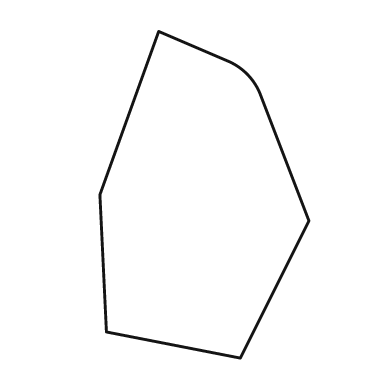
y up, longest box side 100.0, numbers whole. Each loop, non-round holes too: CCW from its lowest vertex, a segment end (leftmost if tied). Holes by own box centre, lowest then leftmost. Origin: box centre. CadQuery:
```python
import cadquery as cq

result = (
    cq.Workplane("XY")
    .moveTo(11.0, -50.0)
    .lineTo(32.0, -8.0)
    .lineTo(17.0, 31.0)
    .threePointArc((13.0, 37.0), (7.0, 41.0))
    .lineTo(-14.0, 50.0)
    .lineTo(-32.0, 0.0)
    .lineTo(-30.0, -42.0)
    .close()
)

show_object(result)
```